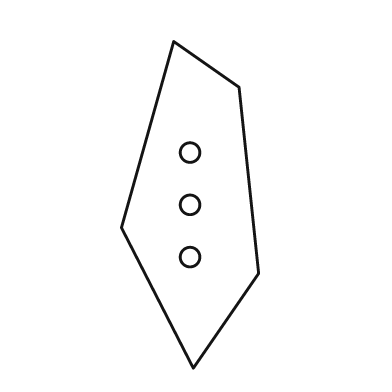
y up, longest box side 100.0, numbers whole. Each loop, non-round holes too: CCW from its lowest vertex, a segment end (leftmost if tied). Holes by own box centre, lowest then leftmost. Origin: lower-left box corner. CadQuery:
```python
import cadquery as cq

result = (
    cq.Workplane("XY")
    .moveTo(22.0, 0.0)
    .lineTo(42.0, 29.0)
    .lineTo(36.0, 86.0)
    .lineTo(16.0, 100.0)
    .lineTo(0.0, 43.0)
    .close()
    .moveTo(21.0, 34.0)
    .circle(3.0)
    .moveTo(21.0, 50.0)
    .circle(3.0)
    .moveTo(21.0, 66.0)
    .circle(3.0)
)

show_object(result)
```